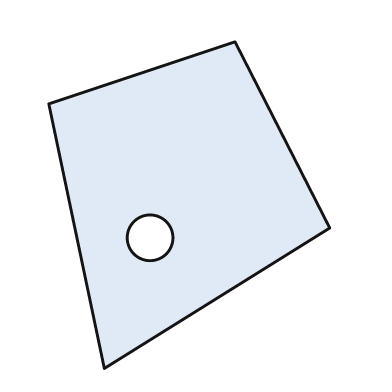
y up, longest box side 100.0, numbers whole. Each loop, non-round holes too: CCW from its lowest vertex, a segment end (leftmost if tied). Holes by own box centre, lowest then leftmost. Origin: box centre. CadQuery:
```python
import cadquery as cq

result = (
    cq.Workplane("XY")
    .moveTo(-26.0, -50.0)
    .lineTo(43.0, -7.0)
    .lineTo(14.0, 50.0)
    .lineTo(-43.0, 31.0)
    .close()
    .moveTo(-12.0, -10.0)
    .circle(7.0)
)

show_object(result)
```